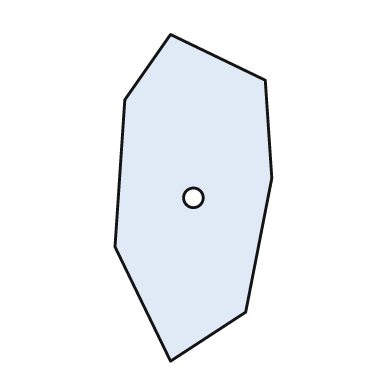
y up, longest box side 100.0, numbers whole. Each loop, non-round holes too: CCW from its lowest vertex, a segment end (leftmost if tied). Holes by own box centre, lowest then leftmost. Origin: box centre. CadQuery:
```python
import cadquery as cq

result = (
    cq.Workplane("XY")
    .moveTo(-7.0, -50.0)
    .lineTo(16.0, -35.0)
    .lineTo(24.0, 6.0)
    .lineTo(22.0, 36.0)
    .lineTo(-7.0, 50.0)
    .lineTo(-21.0, 30.0)
    .lineTo(-24.0, -15.0)
    .close()
    .moveTo(0.0, 0.0)
    .circle(3.0)
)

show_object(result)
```